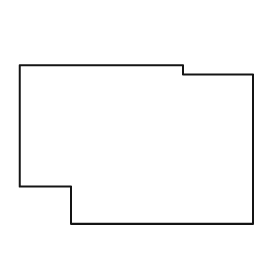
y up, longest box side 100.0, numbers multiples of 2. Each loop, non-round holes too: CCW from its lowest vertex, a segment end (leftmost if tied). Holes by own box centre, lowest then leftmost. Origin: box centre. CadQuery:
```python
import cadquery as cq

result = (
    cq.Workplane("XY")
    .moveTo(-28.0, -34.0)
    .lineTo(50.0, -34.0)
    .lineTo(50.0, 30.0)
    .lineTo(20.0, 30.0)
    .lineTo(20.0, 34.0)
    .lineTo(-50.0, 34.0)
    .lineTo(-50.0, -18.0)
    .lineTo(-28.0, -18.0)
    .close()
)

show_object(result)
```